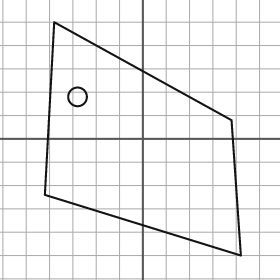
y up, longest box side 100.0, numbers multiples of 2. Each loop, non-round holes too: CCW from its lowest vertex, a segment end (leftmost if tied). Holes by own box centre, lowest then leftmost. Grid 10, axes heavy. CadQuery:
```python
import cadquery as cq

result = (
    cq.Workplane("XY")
    .moveTo(42.0, -50.0)
    .lineTo(38.0, 8.0)
    .lineTo(-38.0, 50.0)
    .lineTo(-42.0, -24.0)
    .close()
    .moveTo(-28.0, 18.0)
    .circle(4.0)
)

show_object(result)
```